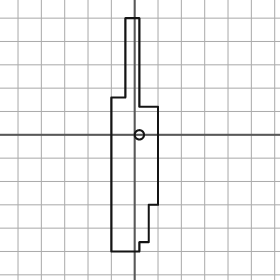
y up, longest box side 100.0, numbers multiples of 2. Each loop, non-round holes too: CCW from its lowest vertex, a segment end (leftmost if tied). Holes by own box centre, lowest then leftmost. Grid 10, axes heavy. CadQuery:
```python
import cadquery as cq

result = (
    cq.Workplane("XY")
    .moveTo(-10.0, -50.0)
    .lineTo(2.0, -50.0)
    .lineTo(2.0, -46.0)
    .lineTo(6.0, -46.0)
    .lineTo(6.0, -30.0)
    .lineTo(10.0, -30.0)
    .lineTo(10.0, 12.0)
    .lineTo(2.0, 12.0)
    .lineTo(2.0, 50.0)
    .lineTo(-4.0, 50.0)
    .lineTo(-4.0, 16.0)
    .lineTo(-10.0, 16.0)
    .close()
    .moveTo(2.0, 0.0)
    .circle(2.0)
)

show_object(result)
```